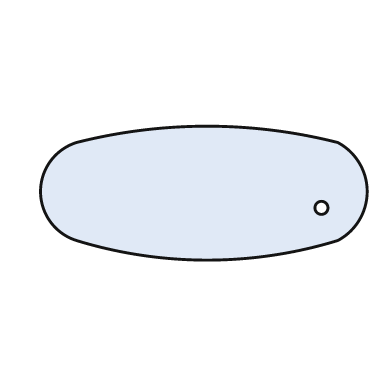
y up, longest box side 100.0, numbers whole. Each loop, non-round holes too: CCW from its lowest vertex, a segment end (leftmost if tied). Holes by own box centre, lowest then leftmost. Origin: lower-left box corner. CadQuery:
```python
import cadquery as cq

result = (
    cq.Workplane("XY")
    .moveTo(11.0, 6.0)
    .threePointArc((51.0, 0.0), (91.0, 6.0))
    .threePointArc((100.0, 21.0), (91.0, 36.0))
    .threePointArc((51.0, 41.0), (11.0, 36.0))
    .threePointArc((0.0, 21.0), (11.0, 6.0))
    .close()
    .moveTo(86.0, 16.0)
    .circle(2.0)
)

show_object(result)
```